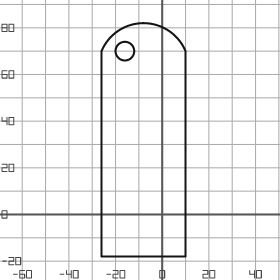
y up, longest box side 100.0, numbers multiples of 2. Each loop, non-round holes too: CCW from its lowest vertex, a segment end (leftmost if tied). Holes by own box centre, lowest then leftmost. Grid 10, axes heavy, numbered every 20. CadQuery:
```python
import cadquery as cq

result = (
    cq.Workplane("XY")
    .moveTo(-26.0, -18.0)
    .lineTo(10.0, -18.0)
    .lineTo(10.0, 70.0)
    .threePointArc((-8.0, 82.0), (-26.0, 70.0))
    .close()
    .moveTo(-16.0, 70.0)
    .circle(4.0)
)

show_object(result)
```